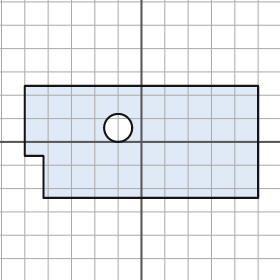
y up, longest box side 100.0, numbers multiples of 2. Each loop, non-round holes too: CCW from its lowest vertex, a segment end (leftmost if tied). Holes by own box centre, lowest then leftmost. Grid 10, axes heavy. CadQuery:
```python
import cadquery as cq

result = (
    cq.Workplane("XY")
    .moveTo(-42.0, -24.0)
    .lineTo(50.0, -24.0)
    .lineTo(50.0, 24.0)
    .lineTo(-50.0, 24.0)
    .lineTo(-50.0, -6.0)
    .lineTo(-42.0, -6.0)
    .close()
    .moveTo(-10.0, 6.0)
    .circle(6.0)
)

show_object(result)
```